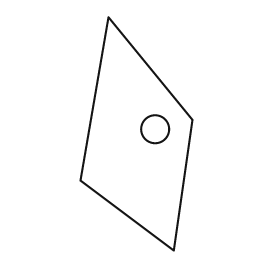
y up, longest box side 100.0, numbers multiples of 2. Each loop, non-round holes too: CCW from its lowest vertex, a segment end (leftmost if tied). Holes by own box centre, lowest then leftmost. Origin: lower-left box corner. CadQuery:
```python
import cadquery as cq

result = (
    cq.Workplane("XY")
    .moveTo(40.0, 0.0)
    .lineTo(48.0, 56.0)
    .lineTo(12.0, 100.0)
    .lineTo(0.0, 30.0)
    .close()
    .moveTo(32.0, 52.0)
    .circle(6.0)
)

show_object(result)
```